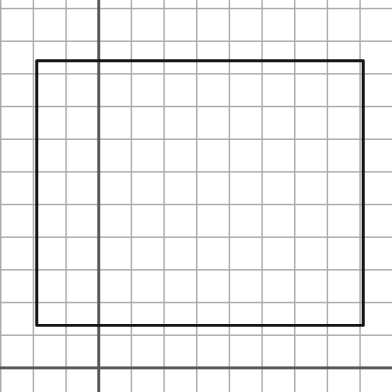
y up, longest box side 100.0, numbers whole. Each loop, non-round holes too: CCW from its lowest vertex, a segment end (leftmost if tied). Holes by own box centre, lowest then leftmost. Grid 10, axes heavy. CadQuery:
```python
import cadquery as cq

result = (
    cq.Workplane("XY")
    .moveTo(-19.0, 13.0)
    .lineTo(81.0, 13.0)
    .lineTo(81.0, 94.0)
    .lineTo(-19.0, 94.0)
    .close()
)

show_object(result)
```